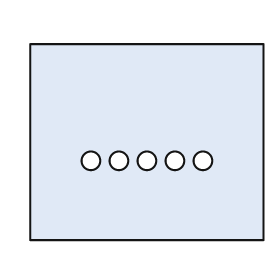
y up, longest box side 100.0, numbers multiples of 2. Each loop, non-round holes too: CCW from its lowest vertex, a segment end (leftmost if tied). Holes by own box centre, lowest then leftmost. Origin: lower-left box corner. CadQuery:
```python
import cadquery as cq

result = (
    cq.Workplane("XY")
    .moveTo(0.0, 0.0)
    .lineTo(100.0, 0.0)
    .lineTo(100.0, 84.0)
    .lineTo(0.0, 84.0)
    .close()
    .moveTo(26.0, 34.0)
    .circle(4.0)
    .moveTo(38.0, 34.0)
    .circle(4.0)
    .moveTo(50.0, 34.0)
    .circle(4.0)
    .moveTo(62.0, 34.0)
    .circle(4.0)
    .moveTo(74.0, 34.0)
    .circle(4.0)
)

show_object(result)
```